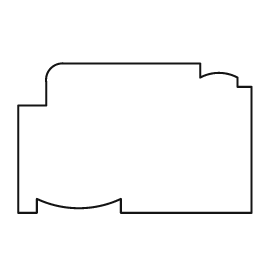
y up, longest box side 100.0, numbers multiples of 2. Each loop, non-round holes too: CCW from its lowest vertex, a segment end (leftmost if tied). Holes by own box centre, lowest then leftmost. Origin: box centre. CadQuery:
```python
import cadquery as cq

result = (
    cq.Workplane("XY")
    .moveTo(-50.0, -32.0)
    .lineTo(-42.0, -32.0)
    .lineTo(-42.0, -26.0)
    .threePointArc((-24.0, -30.0), (-6.0, -26.0))
    .lineTo(-6.0, -32.0)
    .lineTo(50.0, -32.0)
    .lineTo(50.0, 22.0)
    .lineTo(44.0, 22.0)
    .lineTo(44.0, 26.0)
    .threePointArc((36.0, 28.0), (28.0, 26.0))
    .lineTo(28.0, 32.0)
    .lineTo(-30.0, 32.0)
    .threePointArc((-36.0, 30.0), (-38.0, 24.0))
    .lineTo(-38.0, 14.0)
    .lineTo(-50.0, 14.0)
    .close()
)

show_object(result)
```